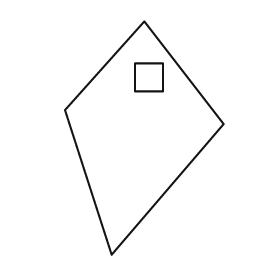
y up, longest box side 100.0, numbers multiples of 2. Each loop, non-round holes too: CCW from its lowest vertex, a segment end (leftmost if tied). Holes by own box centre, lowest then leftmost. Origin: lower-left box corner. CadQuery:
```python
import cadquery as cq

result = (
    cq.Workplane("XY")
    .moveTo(20.0, 0.0)
    .lineTo(68.0, 56.0)
    .lineTo(34.0, 100.0)
    .lineTo(0.0, 62.0)
    .close()
    .moveTo(30.0, 70.0)
    .lineTo(42.0, 70.0)
    .lineTo(42.0, 82.0)
    .lineTo(30.0, 82.0)
    .close()
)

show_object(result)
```